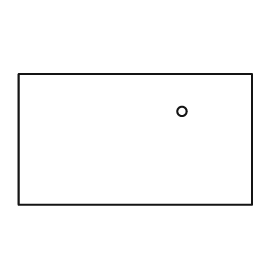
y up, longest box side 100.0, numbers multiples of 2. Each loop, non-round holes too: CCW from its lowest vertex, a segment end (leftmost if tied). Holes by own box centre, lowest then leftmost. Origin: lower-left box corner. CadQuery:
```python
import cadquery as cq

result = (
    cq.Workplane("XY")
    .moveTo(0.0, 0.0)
    .lineTo(100.0, 0.0)
    .lineTo(100.0, 56.0)
    .lineTo(0.0, 56.0)
    .close()
    .moveTo(70.0, 40.0)
    .circle(2.0)
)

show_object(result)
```